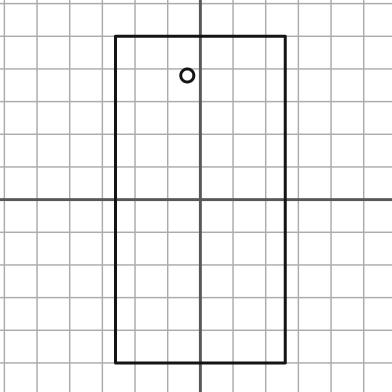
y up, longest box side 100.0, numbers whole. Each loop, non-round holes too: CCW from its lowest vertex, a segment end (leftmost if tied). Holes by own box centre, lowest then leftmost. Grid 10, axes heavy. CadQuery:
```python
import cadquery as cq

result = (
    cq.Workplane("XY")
    .moveTo(-26.0, -50.0)
    .lineTo(26.0, -50.0)
    .lineTo(26.0, 50.0)
    .lineTo(-26.0, 50.0)
    .close()
    .moveTo(-4.0, 38.0)
    .circle(2.0)
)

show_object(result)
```